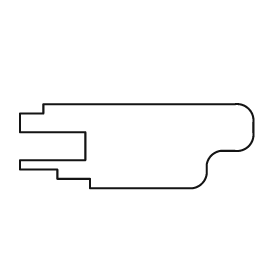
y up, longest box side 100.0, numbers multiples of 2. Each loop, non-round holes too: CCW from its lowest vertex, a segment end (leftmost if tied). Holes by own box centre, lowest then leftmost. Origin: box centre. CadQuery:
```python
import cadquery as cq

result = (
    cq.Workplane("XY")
    .moveTo(-20.0, -18.0)
    .lineTo(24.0, -18.0)
    .threePointArc((28.0, -16.0), (30.0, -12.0))
    .lineTo(30.0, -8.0)
    .threePointArc((32.0, -4.0), (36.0, -2.0))
    .lineTo(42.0, -2.0)
    .threePointArc((48.0, 0.0), (50.0, 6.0))
    .lineTo(50.0, 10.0)
    .threePointArc((48.0, 16.0), (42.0, 18.0))
    .lineTo(-40.0, 18.0)
    .lineTo(-40.0, 14.0)
    .lineTo(-50.0, 14.0)
    .lineTo(-50.0, 6.0)
    .lineTo(-22.0, 6.0)
    .lineTo(-22.0, -6.0)
    .lineTo(-50.0, -6.0)
    .lineTo(-50.0, -10.0)
    .lineTo(-34.0, -10.0)
    .lineTo(-34.0, -14.0)
    .lineTo(-20.0, -14.0)
    .close()
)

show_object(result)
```